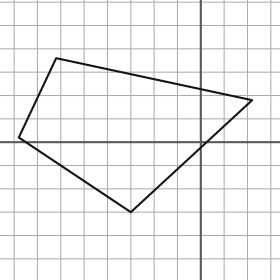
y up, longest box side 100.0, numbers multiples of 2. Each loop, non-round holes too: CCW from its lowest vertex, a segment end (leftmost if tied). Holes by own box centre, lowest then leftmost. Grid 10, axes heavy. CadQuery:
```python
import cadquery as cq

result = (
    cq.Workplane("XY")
    .moveTo(-30.0, -30.0)
    .lineTo(22.0, 18.0)
    .lineTo(-62.0, 36.0)
    .lineTo(-78.0, 2.0)
    .close()
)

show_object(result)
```